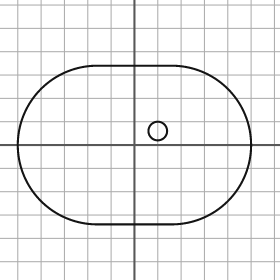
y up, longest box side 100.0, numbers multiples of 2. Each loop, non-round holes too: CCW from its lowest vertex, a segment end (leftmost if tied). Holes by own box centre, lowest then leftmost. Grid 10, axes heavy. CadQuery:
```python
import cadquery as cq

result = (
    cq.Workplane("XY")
    .moveTo(-16.0, -34.0)
    .lineTo(16.0, -34.0)
    .threePointArc((50.0, 0.0), (16.0, 34.0))
    .lineTo(-16.0, 34.0)
    .threePointArc((-50.0, 0.0), (-16.0, -34.0))
    .close()
    .moveTo(10.0, 6.0)
    .circle(4.0)
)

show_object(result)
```